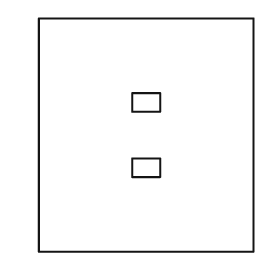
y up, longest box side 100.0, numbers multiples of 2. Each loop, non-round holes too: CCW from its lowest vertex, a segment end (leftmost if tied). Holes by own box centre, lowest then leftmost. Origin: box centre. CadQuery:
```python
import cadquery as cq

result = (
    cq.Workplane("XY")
    .moveTo(-46.0, -50.0)
    .lineTo(46.0, -50.0)
    .lineTo(46.0, 50.0)
    .lineTo(-46.0, 50.0)
    .close()
    .moveTo(-6.0, -18.0)
    .lineTo(6.0, -18.0)
    .lineTo(6.0, -10.0)
    .lineTo(-6.0, -10.0)
    .close()
    .moveTo(-6.0, 10.0)
    .lineTo(6.0, 10.0)
    .lineTo(6.0, 18.0)
    .lineTo(-6.0, 18.0)
    .close()
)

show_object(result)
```